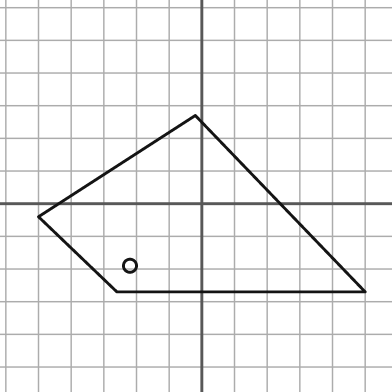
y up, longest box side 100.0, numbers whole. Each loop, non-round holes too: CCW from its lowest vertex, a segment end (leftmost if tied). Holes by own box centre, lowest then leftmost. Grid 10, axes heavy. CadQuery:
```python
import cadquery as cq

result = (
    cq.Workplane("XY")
    .moveTo(-26.0, -27.0)
    .lineTo(50.0, -27.0)
    .lineTo(-2.0, 27.0)
    .lineTo(-50.0, -4.0)
    .close()
    .moveTo(-22.0, -19.0)
    .circle(2.0)
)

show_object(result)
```